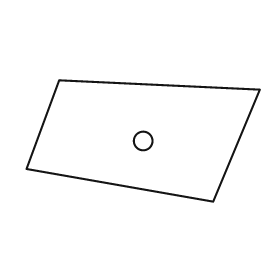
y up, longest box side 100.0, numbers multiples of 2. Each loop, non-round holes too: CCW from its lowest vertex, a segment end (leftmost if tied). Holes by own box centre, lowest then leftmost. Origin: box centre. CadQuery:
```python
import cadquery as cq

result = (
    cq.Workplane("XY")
    .moveTo(30.0, -26.0)
    .lineTo(50.0, 22.0)
    .lineTo(-36.0, 26.0)
    .lineTo(-50.0, -12.0)
    .close()
    .moveTo(0.0, 0.0)
    .circle(4.0)
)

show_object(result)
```